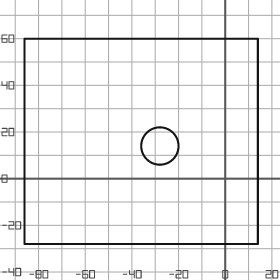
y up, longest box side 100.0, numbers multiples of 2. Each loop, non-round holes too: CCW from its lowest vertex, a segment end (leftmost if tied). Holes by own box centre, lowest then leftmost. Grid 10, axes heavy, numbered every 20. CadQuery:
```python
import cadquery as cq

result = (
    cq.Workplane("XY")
    .moveTo(-86.0, -28.0)
    .lineTo(14.0, -28.0)
    .lineTo(14.0, 60.0)
    .lineTo(-86.0, 60.0)
    .close()
    .moveTo(-28.0, 14.0)
    .circle(8.0)
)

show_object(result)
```